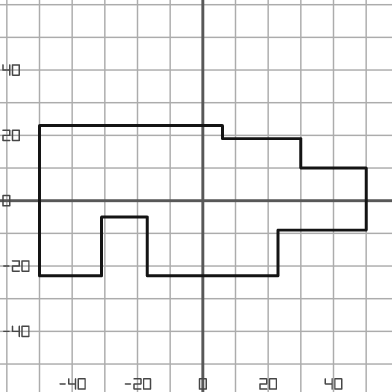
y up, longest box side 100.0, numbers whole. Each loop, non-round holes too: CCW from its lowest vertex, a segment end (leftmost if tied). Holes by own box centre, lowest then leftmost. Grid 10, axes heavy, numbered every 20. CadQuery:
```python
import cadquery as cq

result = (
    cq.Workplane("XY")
    .moveTo(-50.0, -23.0)
    .lineTo(-31.0, -23.0)
    .lineTo(-31.0, -5.0)
    .lineTo(-17.0, -5.0)
    .lineTo(-17.0, -23.0)
    .lineTo(23.0, -23.0)
    .lineTo(23.0, -9.0)
    .lineTo(50.0, -9.0)
    .lineTo(50.0, 10.0)
    .lineTo(30.0, 10.0)
    .lineTo(30.0, 19.0)
    .lineTo(6.0, 19.0)
    .lineTo(6.0, 23.0)
    .lineTo(-50.0, 23.0)
    .close()
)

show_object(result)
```